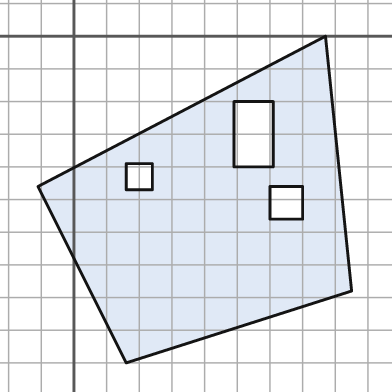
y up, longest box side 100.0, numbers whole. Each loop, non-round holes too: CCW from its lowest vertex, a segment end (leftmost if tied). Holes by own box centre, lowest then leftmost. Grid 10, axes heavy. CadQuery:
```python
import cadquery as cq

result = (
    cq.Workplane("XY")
    .moveTo(16.0, -100.0)
    .lineTo(85.0, -78.0)
    .lineTo(77.0, 0.0)
    .lineTo(-11.0, -46.0)
    .close()
    .moveTo(60.0, -56.0)
    .lineTo(70.0, -56.0)
    .lineTo(70.0, -46.0)
    .lineTo(60.0, -46.0)
    .close()
    .moveTo(16.0, -47.0)
    .lineTo(24.0, -47.0)
    .lineTo(24.0, -39.0)
    .lineTo(16.0, -39.0)
    .close()
    .moveTo(49.0, -40.0)
    .lineTo(61.0, -40.0)
    .lineTo(61.0, -20.0)
    .lineTo(49.0, -20.0)
    .close()
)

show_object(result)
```